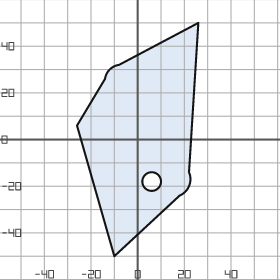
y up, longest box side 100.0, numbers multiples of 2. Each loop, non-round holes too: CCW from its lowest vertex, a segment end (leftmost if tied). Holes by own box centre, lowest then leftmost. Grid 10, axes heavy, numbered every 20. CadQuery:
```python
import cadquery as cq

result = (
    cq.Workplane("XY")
    .moveTo(-10.0, -50.0)
    .lineTo(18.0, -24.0)
    .threePointArc((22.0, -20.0), (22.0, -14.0))
    .lineTo(26.0, 50.0)
    .lineTo(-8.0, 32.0)
    .threePointArc((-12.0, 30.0), (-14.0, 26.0))
    .lineTo(-26.0, 6.0)
    .close()
    .moveTo(6.0, -18.0)
    .circle(4.0)
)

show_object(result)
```